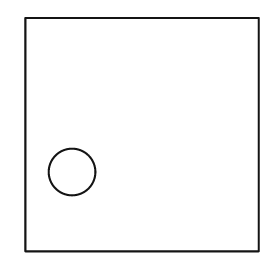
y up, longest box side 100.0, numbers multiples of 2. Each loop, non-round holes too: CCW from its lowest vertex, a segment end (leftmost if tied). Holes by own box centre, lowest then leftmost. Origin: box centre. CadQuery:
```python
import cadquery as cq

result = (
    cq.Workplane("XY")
    .moveTo(-50.0, -50.0)
    .lineTo(50.0, -50.0)
    .lineTo(50.0, 50.0)
    .lineTo(-50.0, 50.0)
    .close()
    .moveTo(-30.0, -16.0)
    .circle(10.0)
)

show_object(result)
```